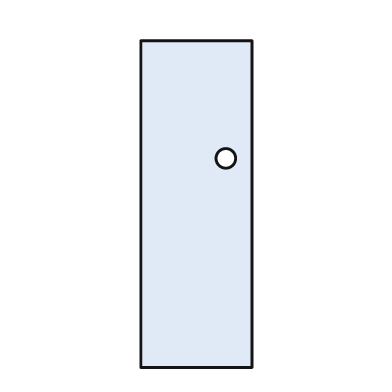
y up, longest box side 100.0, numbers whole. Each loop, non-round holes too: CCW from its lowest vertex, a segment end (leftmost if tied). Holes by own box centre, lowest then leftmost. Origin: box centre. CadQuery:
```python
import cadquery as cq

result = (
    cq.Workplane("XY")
    .moveTo(-17.0, -50.0)
    .lineTo(17.0, -50.0)
    .lineTo(17.0, 50.0)
    .lineTo(-17.0, 50.0)
    .close()
    .moveTo(9.0, 14.0)
    .circle(3.0)
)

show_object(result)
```